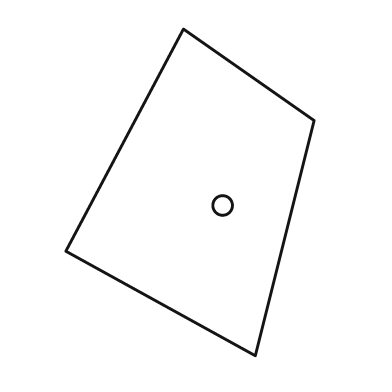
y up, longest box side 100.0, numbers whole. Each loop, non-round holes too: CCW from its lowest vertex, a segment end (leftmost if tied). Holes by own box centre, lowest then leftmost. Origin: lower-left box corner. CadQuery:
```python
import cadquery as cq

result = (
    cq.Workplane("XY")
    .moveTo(58.0, 0.0)
    .lineTo(76.0, 72.0)
    .lineTo(36.0, 100.0)
    .lineTo(0.0, 32.0)
    .close()
    .moveTo(48.0, 46.0)
    .circle(3.0)
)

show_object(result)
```